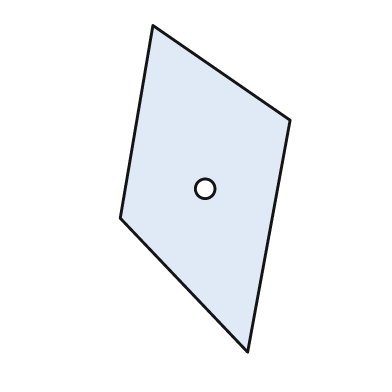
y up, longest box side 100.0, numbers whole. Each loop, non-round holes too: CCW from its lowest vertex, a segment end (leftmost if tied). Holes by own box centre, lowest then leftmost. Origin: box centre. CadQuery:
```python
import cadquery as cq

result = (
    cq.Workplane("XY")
    .moveTo(13.0, -50.0)
    .lineTo(26.0, 21.0)
    .lineTo(-16.0, 50.0)
    .lineTo(-26.0, -9.0)
    .close()
    .moveTo(0.0, 0.0)
    .circle(3.0)
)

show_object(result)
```